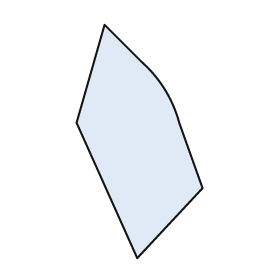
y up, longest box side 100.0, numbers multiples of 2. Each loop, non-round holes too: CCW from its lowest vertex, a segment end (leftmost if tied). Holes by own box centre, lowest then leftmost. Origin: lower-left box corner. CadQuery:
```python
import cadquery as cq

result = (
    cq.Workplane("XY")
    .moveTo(26.0, 0.0)
    .lineTo(54.0, 30.0)
    .lineTo(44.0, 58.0)
    .threePointArc((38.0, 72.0), (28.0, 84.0))
    .lineTo(12.0, 100.0)
    .lineTo(0.0, 58.0)
    .close()
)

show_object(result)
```